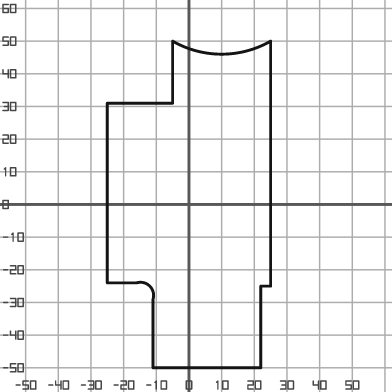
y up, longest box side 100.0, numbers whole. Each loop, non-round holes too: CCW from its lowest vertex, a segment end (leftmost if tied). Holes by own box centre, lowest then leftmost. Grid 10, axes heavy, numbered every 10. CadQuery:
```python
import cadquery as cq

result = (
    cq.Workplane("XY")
    .moveTo(-11.0, -50.0)
    .lineTo(22.0, -50.0)
    .lineTo(22.0, -25.0)
    .lineTo(25.0, -25.0)
    .lineTo(25.0, 50.0)
    .threePointArc((10.0, 46.0), (-5.0, 50.0))
    .lineTo(-5.0, 31.0)
    .lineTo(-25.0, 31.0)
    .lineTo(-25.0, -24.0)
    .lineTo(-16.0, -24.0)
    .threePointArc((-12.0, -25.0), (-11.0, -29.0))
    .close()
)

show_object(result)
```